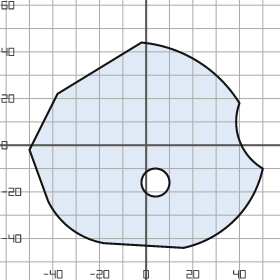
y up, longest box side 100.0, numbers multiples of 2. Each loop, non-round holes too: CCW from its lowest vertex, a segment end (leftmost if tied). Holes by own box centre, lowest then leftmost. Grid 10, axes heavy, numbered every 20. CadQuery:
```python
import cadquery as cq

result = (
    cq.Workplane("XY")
    .moveTo(16.0, -44.0)
    .threePointArc((38.0, -32.0), (50.0, -10.0))
    .threePointArc((40.0, 2.0), (40.0, 18.0))
    .threePointArc((22.0, 36.0), (-2.0, 44.0))
    .lineTo(-38.0, 22.0)
    .lineTo(-50.0, -2.0)
    .lineTo(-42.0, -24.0)
    .threePointArc((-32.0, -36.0), (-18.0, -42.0))
    .close()
    .moveTo(4.0, -16.0)
    .circle(6.0)
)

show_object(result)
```